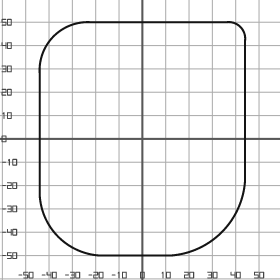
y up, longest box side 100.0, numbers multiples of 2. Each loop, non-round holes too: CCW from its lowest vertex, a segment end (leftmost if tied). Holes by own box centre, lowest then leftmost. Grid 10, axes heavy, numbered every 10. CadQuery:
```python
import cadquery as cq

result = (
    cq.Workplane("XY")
    .moveTo(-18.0, -50.0)
    .lineTo(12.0, -50.0)
    .threePointArc((34.0, -40.0), (44.0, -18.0))
    .lineTo(44.0, 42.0)
    .threePointArc((42.0, 48.0), (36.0, 50.0))
    .lineTo(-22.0, 50.0)
    .threePointArc((-38.0, 44.0), (-44.0, 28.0))
    .lineTo(-44.0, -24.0)
    .threePointArc((-36.0, -42.0), (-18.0, -50.0))
    .close()
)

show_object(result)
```